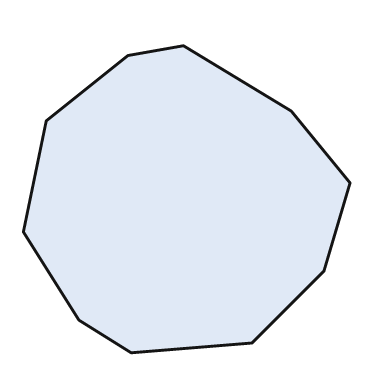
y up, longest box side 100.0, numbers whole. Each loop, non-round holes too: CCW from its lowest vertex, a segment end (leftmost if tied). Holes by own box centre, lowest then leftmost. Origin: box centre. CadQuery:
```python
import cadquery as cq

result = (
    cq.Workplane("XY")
    .moveTo(-17.0, -47.0)
    .lineTo(20.0, -44.0)
    .lineTo(42.0, -22.0)
    .lineTo(50.0, 5.0)
    .lineTo(32.0, 27.0)
    .lineTo(-1.0, 47.0)
    .lineTo(-18.0, 44.0)
    .lineTo(-43.0, 24.0)
    .lineTo(-50.0, -10.0)
    .lineTo(-33.0, -37.0)
    .close()
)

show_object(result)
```